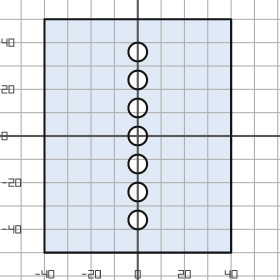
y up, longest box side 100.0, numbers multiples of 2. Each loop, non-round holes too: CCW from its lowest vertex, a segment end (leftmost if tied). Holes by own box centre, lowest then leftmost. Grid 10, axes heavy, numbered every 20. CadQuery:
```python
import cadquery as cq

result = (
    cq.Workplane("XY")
    .moveTo(-40.0, -50.0)
    .lineTo(40.0, -50.0)
    .lineTo(40.0, 50.0)
    .lineTo(-40.0, 50.0)
    .close()
    .moveTo(0.0, -36.0)
    .circle(4.0)
    .moveTo(0.0, -24.0)
    .circle(4.0)
    .moveTo(0.0, -12.0)
    .circle(4.0)
    .moveTo(0.0, 0.0)
    .circle(4.0)
    .moveTo(0.0, 12.0)
    .circle(4.0)
    .moveTo(0.0, 24.0)
    .circle(4.0)
    .moveTo(0.0, 36.0)
    .circle(4.0)
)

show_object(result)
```